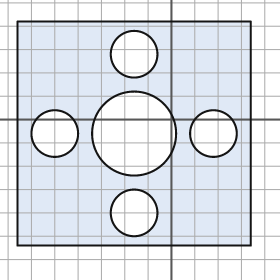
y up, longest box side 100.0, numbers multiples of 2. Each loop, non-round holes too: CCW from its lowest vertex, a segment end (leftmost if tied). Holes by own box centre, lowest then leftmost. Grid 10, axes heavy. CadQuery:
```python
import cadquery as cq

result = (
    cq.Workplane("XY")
    .moveTo(-66.0, -54.0)
    .lineTo(34.0, -54.0)
    .lineTo(34.0, 42.0)
    .lineTo(-66.0, 42.0)
    .close()
    .moveTo(-16.0, -40.0)
    .circle(10.0)
    .moveTo(-50.0, -6.0)
    .circle(10.0)
    .moveTo(-16.0, -6.0)
    .circle(18.0)
    .moveTo(18.0, -6.0)
    .circle(10.0)
    .moveTo(-16.0, 28.0)
    .circle(10.0)
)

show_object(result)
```